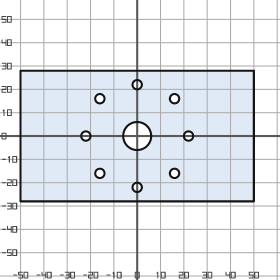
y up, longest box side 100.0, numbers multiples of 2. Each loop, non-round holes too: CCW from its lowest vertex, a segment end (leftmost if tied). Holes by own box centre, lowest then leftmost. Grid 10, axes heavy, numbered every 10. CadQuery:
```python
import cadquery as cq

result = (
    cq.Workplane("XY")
    .moveTo(-50.0, -28.0)
    .lineTo(50.0, -28.0)
    .lineTo(50.0, 28.0)
    .lineTo(-50.0, 28.0)
    .close()
    .moveTo(0.0, -22.0)
    .circle(2.0)
    .moveTo(-16.0, -16.0)
    .circle(2.0)
    .moveTo(16.0, -16.0)
    .circle(2.0)
    .moveTo(-22.0, 0.0)
    .circle(2.0)
    .moveTo(0.0, 0.0)
    .circle(6.0)
    .moveTo(22.0, 0.0)
    .circle(2.0)
    .moveTo(-16.0, 16.0)
    .circle(2.0)
    .moveTo(16.0, 16.0)
    .circle(2.0)
    .moveTo(0.0, 22.0)
    .circle(2.0)
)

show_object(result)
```